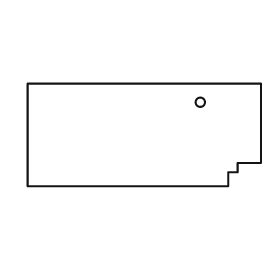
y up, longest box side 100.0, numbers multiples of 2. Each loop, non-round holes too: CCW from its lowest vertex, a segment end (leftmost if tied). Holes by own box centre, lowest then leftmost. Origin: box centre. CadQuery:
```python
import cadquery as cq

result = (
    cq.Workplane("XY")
    .moveTo(-50.0, -22.0)
    .lineTo(36.0, -22.0)
    .lineTo(36.0, -16.0)
    .lineTo(40.0, -16.0)
    .lineTo(40.0, -12.0)
    .lineTo(50.0, -12.0)
    .lineTo(50.0, 22.0)
    .lineTo(-50.0, 22.0)
    .close()
    .moveTo(24.0, 14.0)
    .circle(2.0)
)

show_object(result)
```